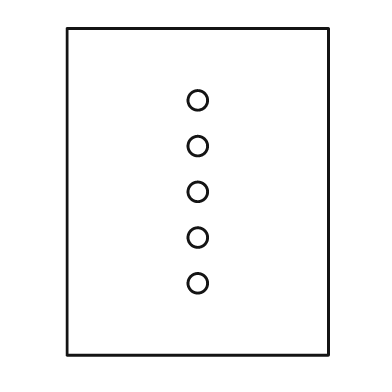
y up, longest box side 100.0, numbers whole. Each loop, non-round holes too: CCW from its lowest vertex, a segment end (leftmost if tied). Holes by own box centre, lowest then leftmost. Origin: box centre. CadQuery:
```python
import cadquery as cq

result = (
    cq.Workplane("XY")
    .moveTo(-40.0, -50.0)
    .lineTo(40.0, -50.0)
    .lineTo(40.0, 50.0)
    .lineTo(-40.0, 50.0)
    .close()
    .moveTo(0.0, -28.0)
    .circle(3.0)
    .moveTo(0.0, -14.0)
    .circle(3.0)
    .moveTo(0.0, 0.0)
    .circle(3.0)
    .moveTo(0.0, 14.0)
    .circle(3.0)
    .moveTo(0.0, 28.0)
    .circle(3.0)
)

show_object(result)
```